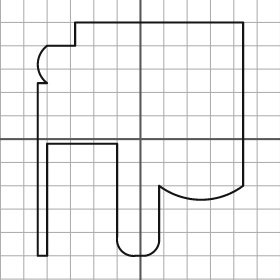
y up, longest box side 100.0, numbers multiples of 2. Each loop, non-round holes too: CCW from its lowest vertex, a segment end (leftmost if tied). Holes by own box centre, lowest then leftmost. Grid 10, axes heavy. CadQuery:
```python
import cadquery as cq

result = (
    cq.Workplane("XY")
    .moveTo(-44.0, -50.0)
    .lineTo(-40.0, -50.0)
    .lineTo(-40.0, -2.0)
    .lineTo(-10.0, -2.0)
    .lineTo(-10.0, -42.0)
    .threePointArc((-8.0, -48.0), (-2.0, -50.0))
    .lineTo(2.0, -50.0)
    .threePointArc((6.0, -48.0), (8.0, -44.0))
    .lineTo(8.0, -20.0)
    .threePointArc((26.0, -26.0), (44.0, -20.0))
    .lineTo(44.0, 50.0)
    .lineTo(-28.0, 50.0)
    .lineTo(-28.0, 40.0)
    .lineTo(-40.0, 40.0)
    .threePointArc((-44.0, 32.0), (-40.0, 24.0))
    .lineTo(-44.0, 24.0)
    .close()
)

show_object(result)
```